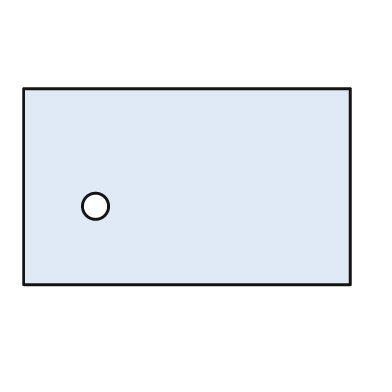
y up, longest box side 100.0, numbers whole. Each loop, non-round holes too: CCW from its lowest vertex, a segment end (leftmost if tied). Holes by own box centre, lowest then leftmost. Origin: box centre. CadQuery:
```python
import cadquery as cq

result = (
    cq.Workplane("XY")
    .moveTo(-50.0, -30.0)
    .lineTo(50.0, -30.0)
    .lineTo(50.0, 30.0)
    .lineTo(-50.0, 30.0)
    .close()
    .moveTo(-28.0, -6.0)
    .circle(4.0)
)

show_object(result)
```